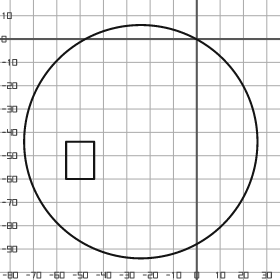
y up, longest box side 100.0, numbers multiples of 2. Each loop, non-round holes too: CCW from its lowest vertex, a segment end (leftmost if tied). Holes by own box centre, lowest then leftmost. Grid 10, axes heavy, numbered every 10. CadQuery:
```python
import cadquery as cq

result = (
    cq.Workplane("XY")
    .moveTo(-24.0, -44.0)
    .circle(50.0)
    .moveTo(-56.0, -60.0)
    .lineTo(-44.0, -60.0)
    .lineTo(-44.0, -44.0)
    .lineTo(-56.0, -44.0)
    .close()
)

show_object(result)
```